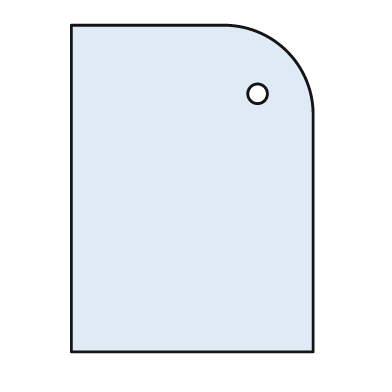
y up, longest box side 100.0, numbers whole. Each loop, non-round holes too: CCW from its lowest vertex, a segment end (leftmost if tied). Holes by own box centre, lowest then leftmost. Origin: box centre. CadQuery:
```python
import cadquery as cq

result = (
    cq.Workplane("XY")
    .moveTo(-37.0, -50.0)
    .lineTo(37.0, -50.0)
    .lineTo(37.0, 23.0)
    .threePointArc((29.0, 42.0), (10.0, 50.0))
    .lineTo(-37.0, 50.0)
    .close()
    .moveTo(20.0, 29.0)
    .circle(3.0)
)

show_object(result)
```